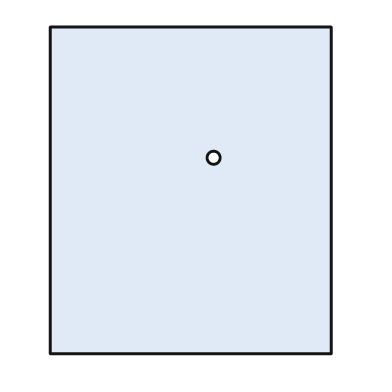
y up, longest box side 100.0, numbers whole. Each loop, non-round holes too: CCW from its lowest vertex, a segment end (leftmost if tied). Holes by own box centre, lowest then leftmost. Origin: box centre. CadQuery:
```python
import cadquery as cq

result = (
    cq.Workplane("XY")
    .moveTo(-43.0, -50.0)
    .lineTo(43.0, -50.0)
    .lineTo(43.0, 50.0)
    .lineTo(-43.0, 50.0)
    .close()
    .moveTo(7.0, 10.0)
    .circle(2.0)
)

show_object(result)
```